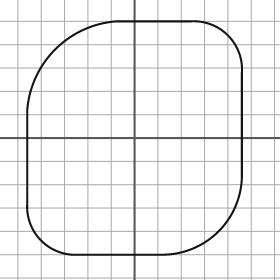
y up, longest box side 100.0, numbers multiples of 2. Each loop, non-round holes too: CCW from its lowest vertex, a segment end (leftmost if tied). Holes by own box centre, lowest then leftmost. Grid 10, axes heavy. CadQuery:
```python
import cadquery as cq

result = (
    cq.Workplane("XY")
    .moveTo(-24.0, -50.0)
    .lineTo(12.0, -50.0)
    .threePointArc((36.0, -40.0), (46.0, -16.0))
    .lineTo(46.0, 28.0)
    .threePointArc((40.0, 44.0), (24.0, 50.0))
    .lineTo(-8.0, 50.0)
    .threePointArc((-34.0, 38.0), (-46.0, 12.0))
    .lineTo(-46.0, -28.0)
    .threePointArc((-40.0, -44.0), (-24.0, -50.0))
    .close()
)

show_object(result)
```